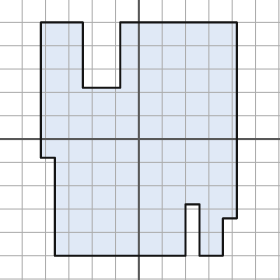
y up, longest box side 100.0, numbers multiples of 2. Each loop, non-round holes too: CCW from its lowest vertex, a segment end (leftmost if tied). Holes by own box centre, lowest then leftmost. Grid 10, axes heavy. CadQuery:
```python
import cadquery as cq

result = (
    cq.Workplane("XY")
    .moveTo(-36.0, -50.0)
    .lineTo(20.0, -50.0)
    .lineTo(20.0, -28.0)
    .lineTo(26.0, -28.0)
    .lineTo(26.0, -50.0)
    .lineTo(36.0, -50.0)
    .lineTo(36.0, -34.0)
    .lineTo(42.0, -34.0)
    .lineTo(42.0, 50.0)
    .lineTo(-8.0, 50.0)
    .lineTo(-8.0, 22.0)
    .lineTo(-24.0, 22.0)
    .lineTo(-24.0, 50.0)
    .lineTo(-42.0, 50.0)
    .lineTo(-42.0, -8.0)
    .lineTo(-36.0, -8.0)
    .close()
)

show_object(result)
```